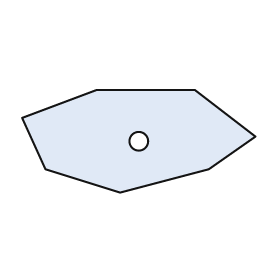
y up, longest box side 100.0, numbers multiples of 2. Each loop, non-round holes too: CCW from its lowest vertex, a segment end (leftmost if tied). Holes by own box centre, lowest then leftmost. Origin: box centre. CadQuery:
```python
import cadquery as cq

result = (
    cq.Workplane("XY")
    .moveTo(-8.0, -22.0)
    .lineTo(30.0, -12.0)
    .lineTo(50.0, 2.0)
    .lineTo(24.0, 22.0)
    .lineTo(-18.0, 22.0)
    .lineTo(-50.0, 10.0)
    .lineTo(-40.0, -12.0)
    .close()
    .moveTo(0.0, 0.0)
    .circle(4.0)
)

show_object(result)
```